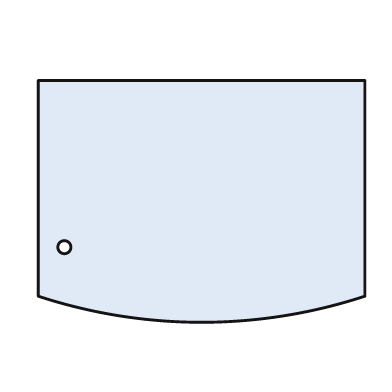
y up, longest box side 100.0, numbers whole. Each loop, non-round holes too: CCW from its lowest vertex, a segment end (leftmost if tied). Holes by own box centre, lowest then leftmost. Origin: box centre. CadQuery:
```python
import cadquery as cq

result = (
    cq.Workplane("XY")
    .moveTo(-50.0, -29.0)
    .threePointArc((0.0, -37.0), (50.0, -29.0))
    .lineTo(50.0, 37.0)
    .lineTo(-50.0, 37.0)
    .close()
    .moveTo(-42.0, -14.0)
    .circle(2.0)
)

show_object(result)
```